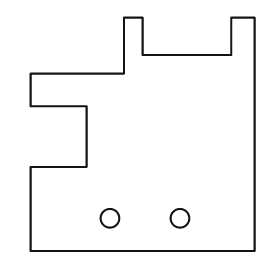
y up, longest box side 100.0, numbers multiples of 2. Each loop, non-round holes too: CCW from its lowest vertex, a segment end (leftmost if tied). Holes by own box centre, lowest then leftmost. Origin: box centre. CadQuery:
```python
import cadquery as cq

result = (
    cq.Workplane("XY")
    .moveTo(-48.0, -50.0)
    .lineTo(48.0, -50.0)
    .lineTo(48.0, 50.0)
    .lineTo(38.0, 50.0)
    .lineTo(38.0, 34.0)
    .lineTo(0.0, 34.0)
    .lineTo(0.0, 50.0)
    .lineTo(-8.0, 50.0)
    .lineTo(-8.0, 26.0)
    .lineTo(-48.0, 26.0)
    .lineTo(-48.0, 12.0)
    .lineTo(-24.0, 12.0)
    .lineTo(-24.0, -14.0)
    .lineTo(-48.0, -14.0)
    .close()
    .moveTo(-14.0, -36.0)
    .circle(4.0)
    .moveTo(16.0, -36.0)
    .circle(4.0)
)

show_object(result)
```